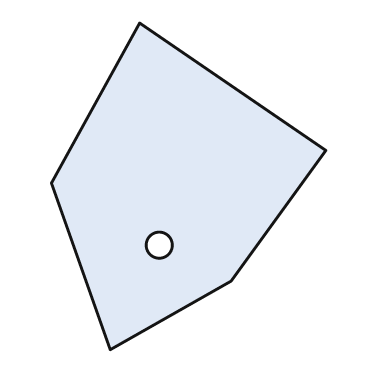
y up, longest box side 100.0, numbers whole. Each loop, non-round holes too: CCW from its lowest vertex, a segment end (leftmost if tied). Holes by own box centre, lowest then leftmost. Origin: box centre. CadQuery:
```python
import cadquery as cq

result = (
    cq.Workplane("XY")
    .moveTo(-24.0, -50.0)
    .lineTo(13.0, -29.0)
    .lineTo(42.0, 11.0)
    .lineTo(-15.0, 50.0)
    .lineTo(-42.0, 1.0)
    .close()
    .moveTo(-9.0, -18.0)
    .circle(4.0)
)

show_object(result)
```